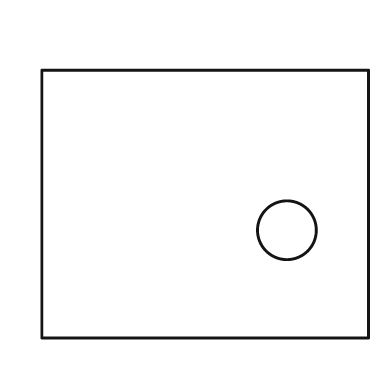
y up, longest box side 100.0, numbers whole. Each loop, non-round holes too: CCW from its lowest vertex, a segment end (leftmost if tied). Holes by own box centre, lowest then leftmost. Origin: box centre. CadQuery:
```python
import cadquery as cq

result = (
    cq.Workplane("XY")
    .moveTo(-50.0, -41.0)
    .lineTo(50.0, -41.0)
    .lineTo(50.0, 41.0)
    .lineTo(-50.0, 41.0)
    .close()
    .moveTo(25.0, -8.0)
    .circle(9.0)
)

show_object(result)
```